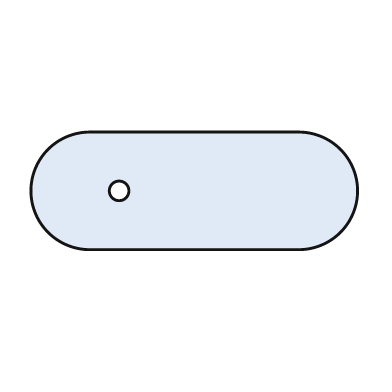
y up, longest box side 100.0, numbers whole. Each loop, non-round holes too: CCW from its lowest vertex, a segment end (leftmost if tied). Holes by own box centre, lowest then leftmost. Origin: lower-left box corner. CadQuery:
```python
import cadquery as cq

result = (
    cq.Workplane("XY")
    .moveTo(18.0, 0.0)
    .lineTo(82.0, 0.0)
    .threePointArc((100.0, 18.0), (82.0, 36.0))
    .lineTo(18.0, 36.0)
    .threePointArc((0.0, 18.0), (18.0, 0.0))
    .close()
    .moveTo(27.0, 18.0)
    .circle(3.0)
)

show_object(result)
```